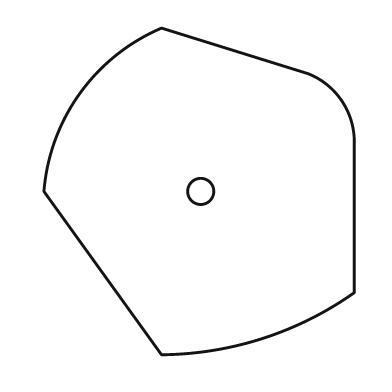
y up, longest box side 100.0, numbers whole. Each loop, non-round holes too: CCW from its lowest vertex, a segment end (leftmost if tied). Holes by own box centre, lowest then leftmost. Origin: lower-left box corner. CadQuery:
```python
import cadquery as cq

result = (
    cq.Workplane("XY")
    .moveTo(36.0, 0.0)
    .threePointArc((67.0, 5.0), (95.0, 19.0))
    .lineTo(95.0, 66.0)
    .threePointArc((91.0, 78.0), (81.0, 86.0))
    .lineTo(36.0, 100.0)
    .threePointArc((11.0, 80.0), (0.0, 50.0))
    .close()
    .moveTo(48.0, 50.0)
    .circle(4.0)
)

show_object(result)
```